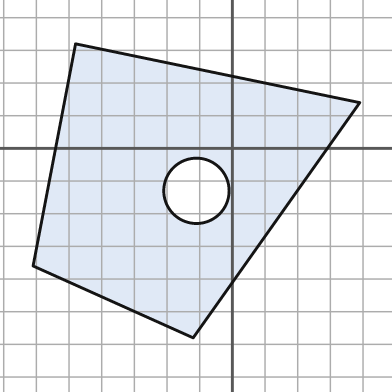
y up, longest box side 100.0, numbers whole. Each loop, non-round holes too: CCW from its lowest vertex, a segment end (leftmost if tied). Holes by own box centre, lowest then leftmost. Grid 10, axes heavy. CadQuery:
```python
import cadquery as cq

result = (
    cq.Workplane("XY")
    .moveTo(-12.0, -58.0)
    .lineTo(39.0, 14.0)
    .lineTo(-48.0, 32.0)
    .lineTo(-61.0, -36.0)
    .close()
    .moveTo(-11.0, -13.0)
    .circle(10.0)
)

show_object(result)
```